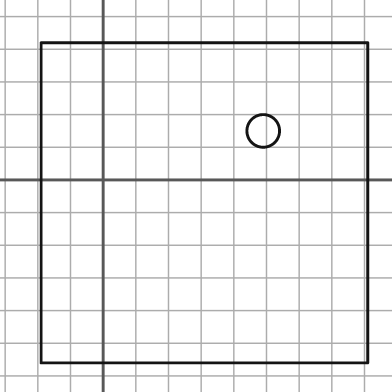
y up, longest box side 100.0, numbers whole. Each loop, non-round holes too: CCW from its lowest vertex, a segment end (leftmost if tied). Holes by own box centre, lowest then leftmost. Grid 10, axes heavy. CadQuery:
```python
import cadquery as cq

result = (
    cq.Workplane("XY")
    .moveTo(-19.0, -56.0)
    .lineTo(81.0, -56.0)
    .lineTo(81.0, 42.0)
    .lineTo(-19.0, 42.0)
    .close()
    .moveTo(49.0, 15.0)
    .circle(5.0)
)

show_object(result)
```